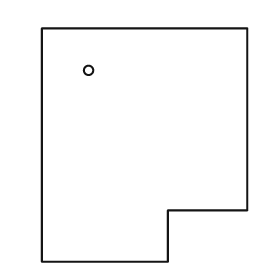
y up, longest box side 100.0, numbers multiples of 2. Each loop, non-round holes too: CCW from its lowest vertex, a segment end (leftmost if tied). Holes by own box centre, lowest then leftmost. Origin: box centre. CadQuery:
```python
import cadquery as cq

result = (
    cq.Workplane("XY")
    .moveTo(-44.0, -50.0)
    .lineTo(10.0, -50.0)
    .lineTo(10.0, -28.0)
    .lineTo(44.0, -28.0)
    .lineTo(44.0, 50.0)
    .lineTo(-44.0, 50.0)
    .close()
    .moveTo(-24.0, 32.0)
    .circle(2.0)
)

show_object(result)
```